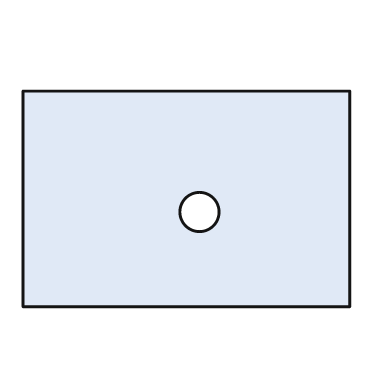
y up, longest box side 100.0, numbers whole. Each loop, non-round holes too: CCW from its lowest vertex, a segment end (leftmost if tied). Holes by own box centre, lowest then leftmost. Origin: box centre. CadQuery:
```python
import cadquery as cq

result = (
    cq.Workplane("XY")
    .moveTo(-50.0, -33.0)
    .lineTo(50.0, -33.0)
    .lineTo(50.0, 33.0)
    .lineTo(-50.0, 33.0)
    .close()
    .moveTo(4.0, -4.0)
    .circle(6.0)
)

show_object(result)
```